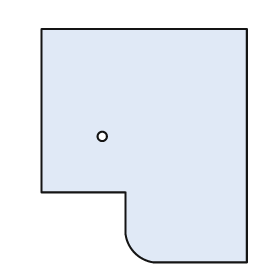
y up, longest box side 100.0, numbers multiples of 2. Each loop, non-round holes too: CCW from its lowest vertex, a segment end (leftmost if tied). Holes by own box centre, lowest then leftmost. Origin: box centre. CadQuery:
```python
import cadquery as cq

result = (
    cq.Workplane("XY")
    .moveTo(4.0, -50.0)
    .lineTo(44.0, -50.0)
    .lineTo(44.0, 50.0)
    .lineTo(-44.0, 50.0)
    .lineTo(-44.0, -20.0)
    .lineTo(-8.0, -20.0)
    .lineTo(-8.0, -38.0)
    .threePointArc((-4.0, -46.0), (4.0, -50.0))
    .close()
    .moveTo(-18.0, 4.0)
    .circle(2.0)
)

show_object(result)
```